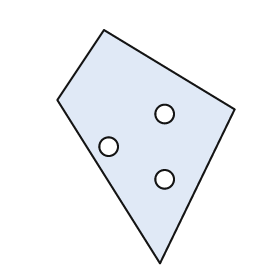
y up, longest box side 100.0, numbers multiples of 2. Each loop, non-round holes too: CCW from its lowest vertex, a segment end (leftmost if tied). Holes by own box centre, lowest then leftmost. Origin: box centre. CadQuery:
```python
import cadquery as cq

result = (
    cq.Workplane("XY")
    .moveTo(6.0, -50.0)
    .lineTo(38.0, 16.0)
    .lineTo(-18.0, 50.0)
    .lineTo(-38.0, 20.0)
    .close()
    .moveTo(8.0, -14.0)
    .circle(4.0)
    .moveTo(-16.0, 0.0)
    .circle(4.0)
    .moveTo(8.0, 14.0)
    .circle(4.0)
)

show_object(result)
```